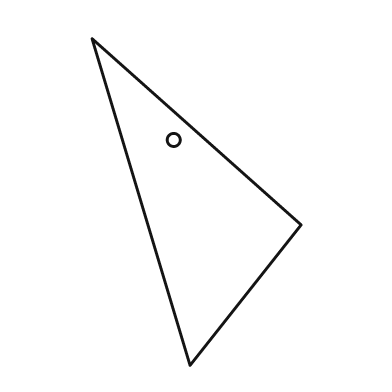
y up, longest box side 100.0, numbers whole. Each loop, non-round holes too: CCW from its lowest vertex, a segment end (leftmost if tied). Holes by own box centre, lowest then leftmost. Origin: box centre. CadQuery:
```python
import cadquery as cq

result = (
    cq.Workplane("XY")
    .moveTo(-2.0, -50.0)
    .lineTo(32.0, -7.0)
    .lineTo(-32.0, 50.0)
    .close()
    .moveTo(-7.0, 19.0)
    .circle(2.0)
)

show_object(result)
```